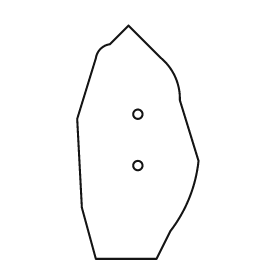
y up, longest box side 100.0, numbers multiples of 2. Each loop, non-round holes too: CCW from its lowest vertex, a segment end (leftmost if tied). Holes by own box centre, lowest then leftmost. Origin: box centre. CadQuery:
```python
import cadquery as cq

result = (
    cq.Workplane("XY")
    .moveTo(-18.0, -50.0)
    .lineTo(8.0, -50.0)
    .lineTo(14.0, -38.0)
    .threePointArc((22.0, -24.0), (26.0, -8.0))
    .lineTo(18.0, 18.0)
    .threePointArc((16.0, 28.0), (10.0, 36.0))
    .lineTo(-4.0, 50.0)
    .lineTo(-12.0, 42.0)
    .threePointArc((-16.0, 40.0), (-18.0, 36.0))
    .lineTo(-26.0, 10.0)
    .lineTo(-24.0, -28.0)
    .close()
    .moveTo(0.0, -10.0)
    .circle(2.0)
    .moveTo(0.0, 12.0)
    .circle(2.0)
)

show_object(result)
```